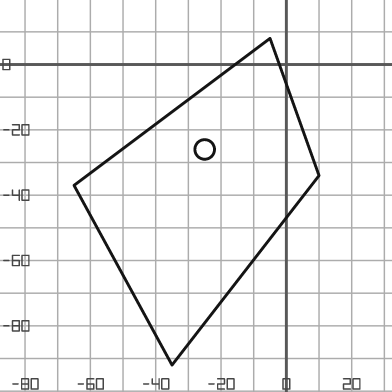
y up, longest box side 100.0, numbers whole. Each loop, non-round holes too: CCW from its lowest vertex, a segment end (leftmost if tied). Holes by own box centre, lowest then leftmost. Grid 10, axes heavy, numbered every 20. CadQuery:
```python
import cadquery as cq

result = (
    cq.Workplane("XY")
    .moveTo(-35.0, -92.0)
    .lineTo(10.0, -34.0)
    .lineTo(-5.0, 8.0)
    .lineTo(-65.0, -37.0)
    .close()
    .moveTo(-25.0, -26.0)
    .circle(3.0)
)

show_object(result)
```